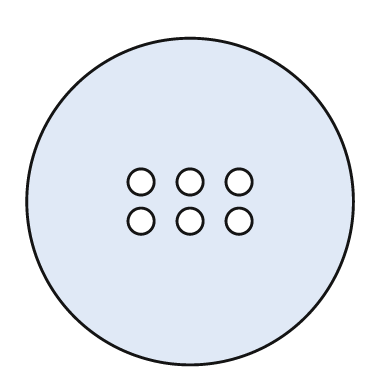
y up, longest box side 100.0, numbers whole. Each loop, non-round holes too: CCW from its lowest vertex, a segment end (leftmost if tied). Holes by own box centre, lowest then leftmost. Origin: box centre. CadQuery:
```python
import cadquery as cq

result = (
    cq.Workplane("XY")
    .moveTo(0.0, 0.0)
    .circle(50.0)
    .moveTo(-15.0, -6.0)
    .circle(4.0)
    .moveTo(0.0, -6.0)
    .circle(4.0)
    .moveTo(15.0, -6.0)
    .circle(4.0)
    .moveTo(-15.0, 6.0)
    .circle(4.0)
    .moveTo(0.0, 6.0)
    .circle(4.0)
    .moveTo(15.0, 6.0)
    .circle(4.0)
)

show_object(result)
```